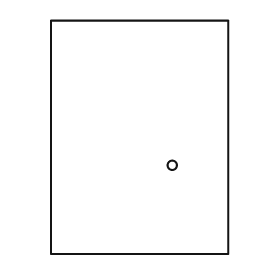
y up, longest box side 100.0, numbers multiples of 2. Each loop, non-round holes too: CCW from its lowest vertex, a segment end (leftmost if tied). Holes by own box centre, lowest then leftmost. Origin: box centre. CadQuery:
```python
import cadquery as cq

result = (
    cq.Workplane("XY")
    .moveTo(-38.0, -50.0)
    .lineTo(38.0, -50.0)
    .lineTo(38.0, 50.0)
    .lineTo(-38.0, 50.0)
    .close()
    .moveTo(14.0, -12.0)
    .circle(2.0)
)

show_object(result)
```